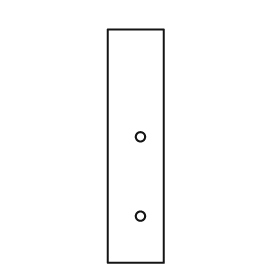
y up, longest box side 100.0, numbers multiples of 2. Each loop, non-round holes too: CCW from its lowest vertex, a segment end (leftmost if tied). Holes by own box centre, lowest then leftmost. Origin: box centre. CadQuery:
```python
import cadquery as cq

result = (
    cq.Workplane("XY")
    .moveTo(-12.0, -50.0)
    .lineTo(12.0, -50.0)
    .lineTo(12.0, 50.0)
    .lineTo(-12.0, 50.0)
    .close()
    .moveTo(2.0, -30.0)
    .circle(2.0)
    .moveTo(2.0, 4.0)
    .circle(2.0)
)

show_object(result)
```